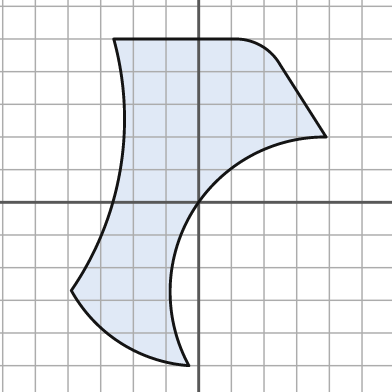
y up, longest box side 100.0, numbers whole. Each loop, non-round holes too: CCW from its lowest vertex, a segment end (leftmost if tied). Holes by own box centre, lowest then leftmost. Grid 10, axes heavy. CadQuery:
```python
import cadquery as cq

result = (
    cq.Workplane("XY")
    .moveTo(-3.0, -50.0)
    .threePointArc((-2.0, -3.0), (39.0, 20.0))
    .lineTo(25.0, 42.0)
    .threePointArc((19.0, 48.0), (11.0, 50.0))
    .lineTo(-26.0, 50.0)
    .threePointArc((-24.0, 10.0), (-39.0, -27.0))
    .threePointArc((-24.0, -43.0), (-3.0, -50.0))
    .close()
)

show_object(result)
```